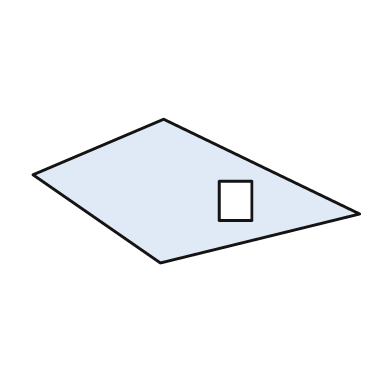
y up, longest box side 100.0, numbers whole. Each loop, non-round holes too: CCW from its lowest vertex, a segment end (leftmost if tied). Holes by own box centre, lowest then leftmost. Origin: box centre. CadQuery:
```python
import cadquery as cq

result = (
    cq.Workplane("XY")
    .moveTo(-11.0, -22.0)
    .lineTo(50.0, -7.0)
    .lineTo(-10.0, 22.0)
    .lineTo(-50.0, 5.0)
    .close()
    .moveTo(7.0, -9.0)
    .lineTo(17.0, -9.0)
    .lineTo(17.0, 3.0)
    .lineTo(7.0, 3.0)
    .close()
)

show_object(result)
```